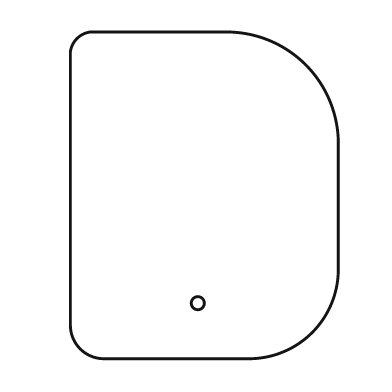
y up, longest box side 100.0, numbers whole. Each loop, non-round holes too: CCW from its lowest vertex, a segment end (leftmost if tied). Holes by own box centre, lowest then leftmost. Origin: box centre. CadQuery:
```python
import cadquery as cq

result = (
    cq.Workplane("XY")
    .moveTo(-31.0, -50.0)
    .lineTo(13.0, -50.0)
    .threePointArc((33.0, -42.0), (41.0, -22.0))
    .lineTo(41.0, 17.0)
    .threePointArc((31.0, 40.0), (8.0, 50.0))
    .lineTo(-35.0, 50.0)
    .threePointArc((-39.0, 48.0), (-41.0, 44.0))
    .lineTo(-41.0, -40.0)
    .threePointArc((-38.0, -47.0), (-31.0, -50.0))
    .close()
    .moveTo(-2.0, -33.0)
    .circle(2.0)
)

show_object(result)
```